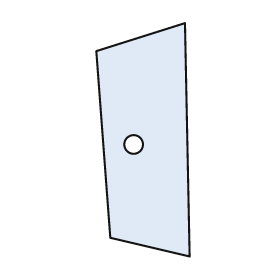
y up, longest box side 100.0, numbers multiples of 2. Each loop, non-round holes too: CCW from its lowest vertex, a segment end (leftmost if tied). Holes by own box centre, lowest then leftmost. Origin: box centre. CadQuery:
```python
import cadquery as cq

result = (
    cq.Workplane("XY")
    .moveTo(20.0, -50.0)
    .lineTo(18.0, 50.0)
    .lineTo(-20.0, 38.0)
    .lineTo(-14.0, -42.0)
    .close()
    .moveTo(-4.0, -2.0)
    .circle(4.0)
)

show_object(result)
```